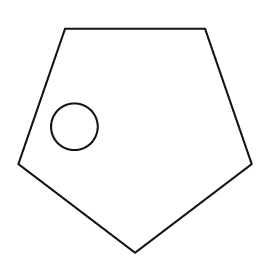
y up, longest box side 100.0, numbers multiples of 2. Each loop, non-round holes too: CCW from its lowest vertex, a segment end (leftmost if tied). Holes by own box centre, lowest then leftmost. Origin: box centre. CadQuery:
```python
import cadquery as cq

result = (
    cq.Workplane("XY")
    .moveTo(0.0, -48.0)
    .lineTo(50.0, -10.0)
    .lineTo(30.0, 48.0)
    .lineTo(-30.0, 48.0)
    .lineTo(-50.0, -10.0)
    .close()
    .moveTo(-26.0, 6.0)
    .circle(10.0)
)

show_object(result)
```